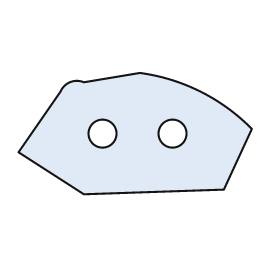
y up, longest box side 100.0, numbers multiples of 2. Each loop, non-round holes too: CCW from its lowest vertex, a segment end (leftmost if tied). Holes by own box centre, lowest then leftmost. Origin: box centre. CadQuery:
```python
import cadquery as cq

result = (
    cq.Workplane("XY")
    .moveTo(-22.0, -26.0)
    .lineTo(38.0, -24.0)
    .lineTo(50.0, 2.0)
    .threePointArc((28.0, 18.0), (2.0, 26.0))
    .lineTo(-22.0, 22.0)
    .threePointArc((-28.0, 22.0), (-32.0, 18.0))
    .lineTo(-50.0, -8.0)
    .close()
    .moveTo(-14.0, 0.0)
    .circle(6.0)
    .moveTo(16.0, 0.0)
    .circle(6.0)
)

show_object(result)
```